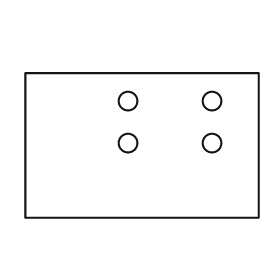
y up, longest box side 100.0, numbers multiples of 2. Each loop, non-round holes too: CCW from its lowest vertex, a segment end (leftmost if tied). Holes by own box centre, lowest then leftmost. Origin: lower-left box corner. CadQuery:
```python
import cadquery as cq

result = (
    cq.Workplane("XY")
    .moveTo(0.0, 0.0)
    .lineTo(100.0, 0.0)
    .lineTo(100.0, 62.0)
    .lineTo(0.0, 62.0)
    .close()
    .moveTo(44.0, 32.0)
    .circle(4.0)
    .moveTo(80.0, 32.0)
    .circle(4.0)
    .moveTo(44.0, 50.0)
    .circle(4.0)
    .moveTo(80.0, 50.0)
    .circle(4.0)
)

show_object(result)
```